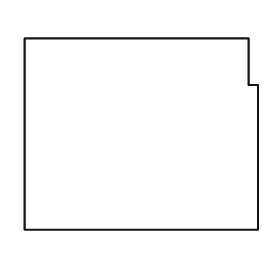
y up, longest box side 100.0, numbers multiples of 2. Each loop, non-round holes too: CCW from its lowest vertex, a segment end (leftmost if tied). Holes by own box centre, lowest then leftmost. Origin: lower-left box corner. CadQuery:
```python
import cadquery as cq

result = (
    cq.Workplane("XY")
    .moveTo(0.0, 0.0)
    .lineTo(100.0, 0.0)
    .lineTo(100.0, 62.0)
    .lineTo(96.0, 62.0)
    .lineTo(96.0, 82.0)
    .lineTo(0.0, 82.0)
    .close()
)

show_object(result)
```